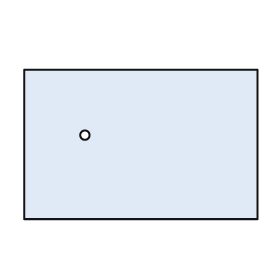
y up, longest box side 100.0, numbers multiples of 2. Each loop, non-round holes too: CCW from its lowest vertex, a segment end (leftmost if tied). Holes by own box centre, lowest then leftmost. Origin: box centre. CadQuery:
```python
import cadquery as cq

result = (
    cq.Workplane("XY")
    .moveTo(-50.0, -32.0)
    .lineTo(50.0, -32.0)
    .lineTo(50.0, 32.0)
    .lineTo(-50.0, 32.0)
    .close()
    .moveTo(-24.0, 4.0)
    .circle(2.0)
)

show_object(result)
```